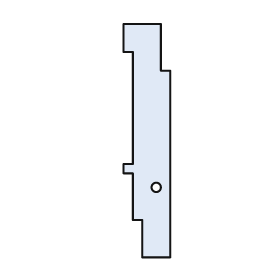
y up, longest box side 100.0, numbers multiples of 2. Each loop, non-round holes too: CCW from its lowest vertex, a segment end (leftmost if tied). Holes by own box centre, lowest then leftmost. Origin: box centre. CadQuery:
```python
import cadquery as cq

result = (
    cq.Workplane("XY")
    .moveTo(-2.0, -50.0)
    .lineTo(10.0, -50.0)
    .lineTo(10.0, 30.0)
    .lineTo(6.0, 30.0)
    .lineTo(6.0, 50.0)
    .lineTo(-10.0, 50.0)
    .lineTo(-10.0, 38.0)
    .lineTo(-6.0, 38.0)
    .lineTo(-6.0, -10.0)
    .lineTo(-10.0, -10.0)
    .lineTo(-10.0, -14.0)
    .lineTo(-6.0, -14.0)
    .lineTo(-6.0, -34.0)
    .lineTo(-2.0, -34.0)
    .close()
    .moveTo(4.0, -20.0)
    .circle(2.0)
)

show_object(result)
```